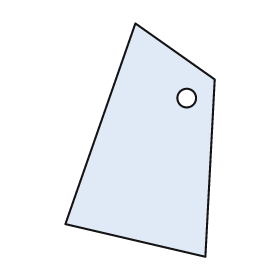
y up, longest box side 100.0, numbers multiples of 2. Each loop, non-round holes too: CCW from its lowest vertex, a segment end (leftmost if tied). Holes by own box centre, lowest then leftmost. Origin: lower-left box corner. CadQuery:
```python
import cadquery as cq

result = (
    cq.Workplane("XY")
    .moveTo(60.0, 0.0)
    .lineTo(64.0, 76.0)
    .lineTo(30.0, 100.0)
    .lineTo(0.0, 14.0)
    .close()
    .moveTo(52.0, 68.0)
    .circle(4.0)
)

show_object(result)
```